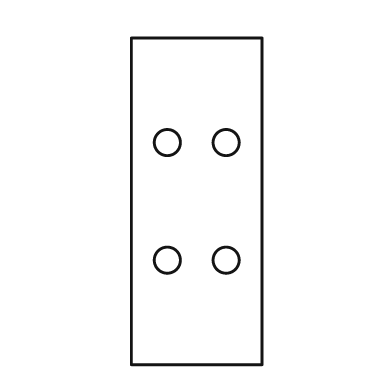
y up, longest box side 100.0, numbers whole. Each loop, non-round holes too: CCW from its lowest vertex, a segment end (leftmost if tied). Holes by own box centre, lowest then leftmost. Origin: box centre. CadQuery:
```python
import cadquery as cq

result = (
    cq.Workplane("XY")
    .moveTo(-20.0, -50.0)
    .lineTo(20.0, -50.0)
    .lineTo(20.0, 50.0)
    .lineTo(-20.0, 50.0)
    .close()
    .moveTo(-9.0, -18.0)
    .circle(4.0)
    .moveTo(9.0, -18.0)
    .circle(4.0)
    .moveTo(-9.0, 18.0)
    .circle(4.0)
    .moveTo(9.0, 18.0)
    .circle(4.0)
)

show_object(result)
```